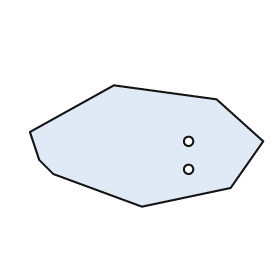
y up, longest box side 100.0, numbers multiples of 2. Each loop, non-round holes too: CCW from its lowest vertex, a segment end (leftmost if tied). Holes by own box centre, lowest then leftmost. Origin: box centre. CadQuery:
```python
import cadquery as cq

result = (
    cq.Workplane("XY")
    .moveTo(-2.0, -26.0)
    .lineTo(36.0, -18.0)
    .lineTo(50.0, 2.0)
    .lineTo(30.0, 20.0)
    .lineTo(-14.0, 26.0)
    .lineTo(-50.0, 6.0)
    .lineTo(-46.0, -6.0)
    .lineTo(-40.0, -12.0)
    .close()
    .moveTo(18.0, -10.0)
    .circle(2.0)
    .moveTo(18.0, 2.0)
    .circle(2.0)
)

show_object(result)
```